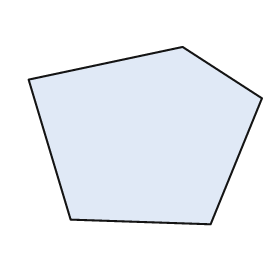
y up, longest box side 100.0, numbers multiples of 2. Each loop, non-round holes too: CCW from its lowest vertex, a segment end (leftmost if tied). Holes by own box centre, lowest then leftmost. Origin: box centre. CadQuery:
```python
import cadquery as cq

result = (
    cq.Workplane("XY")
    .moveTo(28.0, -38.0)
    .lineTo(50.0, 16.0)
    .lineTo(16.0, 38.0)
    .lineTo(-50.0, 24.0)
    .lineTo(-32.0, -36.0)
    .close()
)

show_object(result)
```